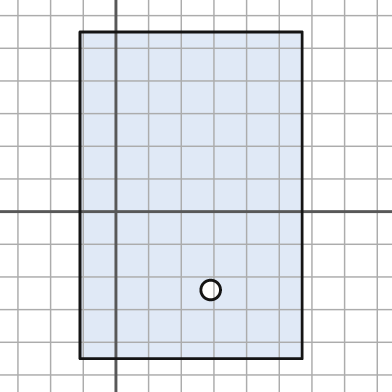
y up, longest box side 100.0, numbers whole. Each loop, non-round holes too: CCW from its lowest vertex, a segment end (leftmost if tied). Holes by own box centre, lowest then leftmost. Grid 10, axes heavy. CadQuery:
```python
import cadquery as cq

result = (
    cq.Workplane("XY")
    .moveTo(-11.0, -45.0)
    .lineTo(57.0, -45.0)
    .lineTo(57.0, 55.0)
    .lineTo(-11.0, 55.0)
    .close()
    .moveTo(29.0, -24.0)
    .circle(3.0)
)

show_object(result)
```